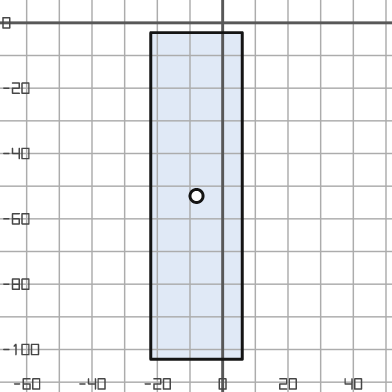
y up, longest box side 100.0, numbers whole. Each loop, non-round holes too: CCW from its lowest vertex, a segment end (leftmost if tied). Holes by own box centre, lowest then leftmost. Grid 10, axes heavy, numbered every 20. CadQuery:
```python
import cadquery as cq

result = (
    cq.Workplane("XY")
    .moveTo(-22.0, -103.0)
    .lineTo(6.0, -103.0)
    .lineTo(6.0, -3.0)
    .lineTo(-22.0, -3.0)
    .close()
    .moveTo(-8.0, -53.0)
    .circle(2.0)
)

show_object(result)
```